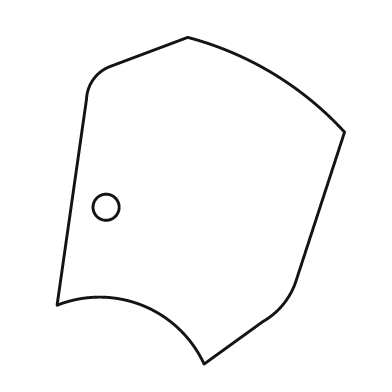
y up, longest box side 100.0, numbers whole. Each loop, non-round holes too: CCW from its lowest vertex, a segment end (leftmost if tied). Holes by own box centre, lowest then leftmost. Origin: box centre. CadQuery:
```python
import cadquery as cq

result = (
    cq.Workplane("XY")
    .moveTo(1.0, -50.0)
    .lineTo(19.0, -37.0)
    .threePointArc((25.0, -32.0), (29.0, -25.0))
    .lineTo(44.0, 21.0)
    .threePointArc((22.0, 39.0), (-4.0, 50.0))
    .lineTo(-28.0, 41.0)
    .threePointArc((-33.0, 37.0), (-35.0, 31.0))
    .lineTo(-44.0, -32.0)
    .threePointArc((-18.0, -32.0), (1.0, -50.0))
    .close()
    .moveTo(-29.0, -2.0)
    .circle(4.0)
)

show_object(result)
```